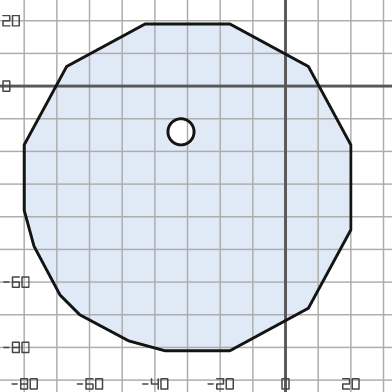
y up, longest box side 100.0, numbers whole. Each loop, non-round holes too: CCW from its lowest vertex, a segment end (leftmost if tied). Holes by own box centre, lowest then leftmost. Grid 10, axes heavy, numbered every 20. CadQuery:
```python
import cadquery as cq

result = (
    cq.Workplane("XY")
    .moveTo(-37.0, -81.0)
    .lineTo(-17.0, -81.0)
    .lineTo(7.0, -68.0)
    .lineTo(20.0, -44.0)
    .lineTo(20.0, -18.0)
    .lineTo(7.0, 6.0)
    .lineTo(-17.0, 19.0)
    .lineTo(-43.0, 19.0)
    .lineTo(-67.0, 6.0)
    .lineTo(-80.0, -18.0)
    .lineTo(-80.0, -38.0)
    .lineTo(-77.0, -49.0)
    .lineTo(-69.0, -64.0)
    .lineTo(-63.0, -70.0)
    .lineTo(-48.0, -78.0)
    .close()
    .moveTo(-32.0, -14.0)
    .circle(4.0)
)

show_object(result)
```